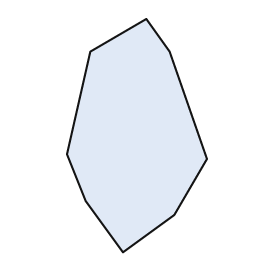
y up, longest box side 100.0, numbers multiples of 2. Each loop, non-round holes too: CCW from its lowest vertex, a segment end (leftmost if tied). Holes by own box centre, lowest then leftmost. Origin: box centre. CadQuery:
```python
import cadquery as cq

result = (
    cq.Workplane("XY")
    .moveTo(-6.0, -50.0)
    .lineTo(16.0, -34.0)
    .lineTo(30.0, -10.0)
    .lineTo(14.0, 36.0)
    .lineTo(4.0, 50.0)
    .lineTo(-20.0, 36.0)
    .lineTo(-30.0, -8.0)
    .lineTo(-22.0, -28.0)
    .close()
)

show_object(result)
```